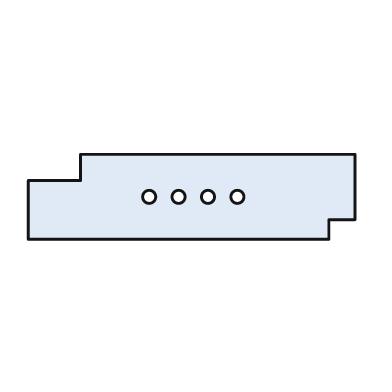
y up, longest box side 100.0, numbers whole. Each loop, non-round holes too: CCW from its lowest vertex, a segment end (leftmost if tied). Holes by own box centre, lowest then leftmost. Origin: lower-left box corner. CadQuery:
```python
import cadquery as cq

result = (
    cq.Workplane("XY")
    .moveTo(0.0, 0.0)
    .lineTo(92.0, 0.0)
    .lineTo(92.0, 6.0)
    .lineTo(100.0, 6.0)
    .lineTo(100.0, 26.0)
    .lineTo(16.0, 26.0)
    .lineTo(16.0, 18.0)
    .lineTo(0.0, 18.0)
    .close()
    .moveTo(37.0, 13.0)
    .circle(2.0)
    .moveTo(46.0, 13.0)
    .circle(2.0)
    .moveTo(55.0, 13.0)
    .circle(2.0)
    .moveTo(64.0, 13.0)
    .circle(2.0)
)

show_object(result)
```